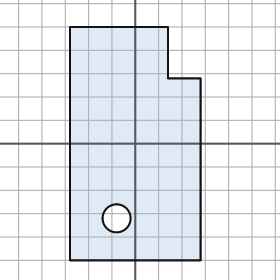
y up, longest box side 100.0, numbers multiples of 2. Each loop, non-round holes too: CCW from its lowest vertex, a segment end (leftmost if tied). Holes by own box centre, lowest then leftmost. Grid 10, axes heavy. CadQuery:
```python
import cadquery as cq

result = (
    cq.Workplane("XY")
    .moveTo(-28.0, -50.0)
    .lineTo(28.0, -50.0)
    .lineTo(28.0, 28.0)
    .lineTo(14.0, 28.0)
    .lineTo(14.0, 50.0)
    .lineTo(-28.0, 50.0)
    .close()
    .moveTo(-8.0, -32.0)
    .circle(6.0)
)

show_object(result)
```